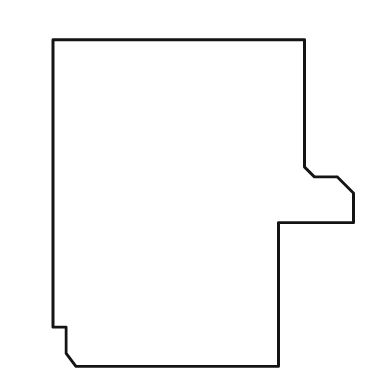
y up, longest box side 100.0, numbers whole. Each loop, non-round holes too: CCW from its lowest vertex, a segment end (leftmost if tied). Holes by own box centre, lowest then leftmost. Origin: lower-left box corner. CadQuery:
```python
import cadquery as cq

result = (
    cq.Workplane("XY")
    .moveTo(7.0, 0.0)
    .lineTo(69.0, 0.0)
    .lineTo(69.0, 44.0)
    .lineTo(92.0, 44.0)
    .lineTo(92.0, 53.0)
    .lineTo(87.0, 58.0)
    .lineTo(80.0, 58.0)
    .lineTo(77.0, 61.0)
    .lineTo(77.0, 100.0)
    .lineTo(0.0, 100.0)
    .lineTo(0.0, 12.0)
    .lineTo(4.0, 12.0)
    .lineTo(4.0, 4.0)
    .close()
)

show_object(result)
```